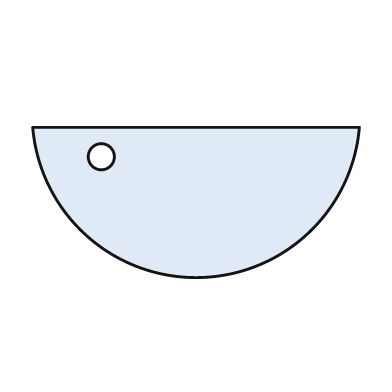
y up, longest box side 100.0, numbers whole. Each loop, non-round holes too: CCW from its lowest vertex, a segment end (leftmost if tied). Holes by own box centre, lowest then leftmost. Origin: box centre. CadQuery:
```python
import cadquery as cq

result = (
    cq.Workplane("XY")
    .moveTo(-50.0, 23.0)
    .threePointArc((0.0, -23.0), (50.0, 23.0))
    .close()
    .moveTo(-29.0, 14.0)
    .circle(4.0)
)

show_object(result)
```